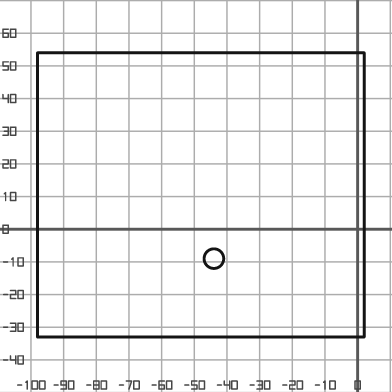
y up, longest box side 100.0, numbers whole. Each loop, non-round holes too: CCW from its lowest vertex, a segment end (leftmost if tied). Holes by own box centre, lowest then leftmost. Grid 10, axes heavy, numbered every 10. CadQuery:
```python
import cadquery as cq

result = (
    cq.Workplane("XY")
    .moveTo(-98.0, -33.0)
    .lineTo(2.0, -33.0)
    .lineTo(2.0, 54.0)
    .lineTo(-98.0, 54.0)
    .close()
    .moveTo(-44.0, -9.0)
    .circle(3.0)
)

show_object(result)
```